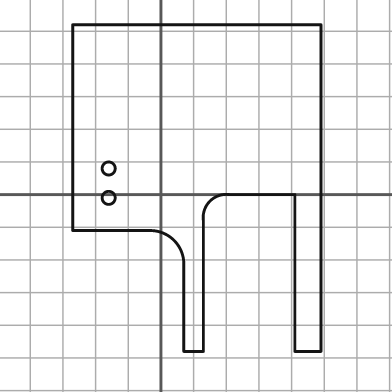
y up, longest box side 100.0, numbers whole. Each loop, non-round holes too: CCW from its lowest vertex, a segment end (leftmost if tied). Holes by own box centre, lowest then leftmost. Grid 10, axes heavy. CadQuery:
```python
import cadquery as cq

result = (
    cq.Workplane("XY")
    .moveTo(7.0, -48.0)
    .lineTo(13.0, -48.0)
    .lineTo(13.0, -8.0)
    .threePointArc((15.0, -2.0), (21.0, 0.0))
    .lineTo(41.0, 0.0)
    .lineTo(41.0, -48.0)
    .lineTo(49.0, -48.0)
    .lineTo(49.0, 52.0)
    .lineTo(-27.0, 52.0)
    .lineTo(-27.0, -11.0)
    .lineTo(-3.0, -11.0)
    .threePointArc((4.0, -14.0), (7.0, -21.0))
    .close()
    .moveTo(-16.0, -1.0)
    .circle(2.0)
    .moveTo(-16.0, 8.0)
    .circle(2.0)
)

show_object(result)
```